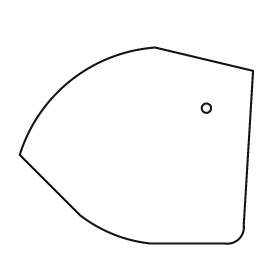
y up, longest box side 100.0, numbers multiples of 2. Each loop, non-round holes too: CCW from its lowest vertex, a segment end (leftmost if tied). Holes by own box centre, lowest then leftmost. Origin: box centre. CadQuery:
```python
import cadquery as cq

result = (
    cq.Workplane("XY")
    .moveTo(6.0, -42.0)
    .lineTo(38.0, -42.0)
    .threePointArc((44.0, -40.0), (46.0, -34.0))
    .lineTo(50.0, 32.0)
    .lineTo(8.0, 42.0)
    .threePointArc((-28.0, 28.0), (-50.0, -4.0))
    .lineTo(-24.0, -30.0)
    .threePointArc((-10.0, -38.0), (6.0, -42.0))
    .close()
    .moveTo(30.0, 16.0)
    .circle(2.0)
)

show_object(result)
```